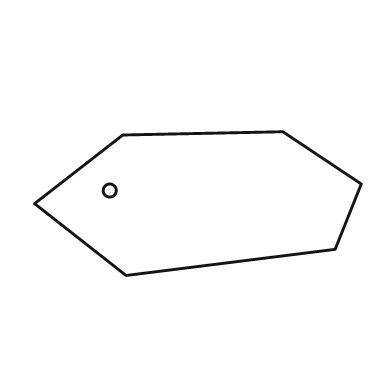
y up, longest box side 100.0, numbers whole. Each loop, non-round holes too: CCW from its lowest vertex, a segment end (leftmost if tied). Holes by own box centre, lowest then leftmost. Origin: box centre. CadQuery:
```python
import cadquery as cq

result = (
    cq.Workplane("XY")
    .moveTo(-22.0, -22.0)
    .lineTo(42.0, -14.0)
    .lineTo(50.0, 6.0)
    .lineTo(26.0, 22.0)
    .lineTo(-23.0, 21.0)
    .lineTo(-50.0, 0.0)
    .close()
    .moveTo(-27.0, 4.0)
    .circle(2.0)
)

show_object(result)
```